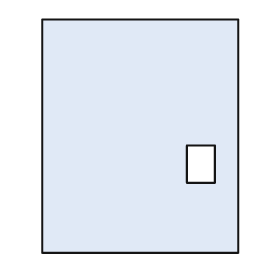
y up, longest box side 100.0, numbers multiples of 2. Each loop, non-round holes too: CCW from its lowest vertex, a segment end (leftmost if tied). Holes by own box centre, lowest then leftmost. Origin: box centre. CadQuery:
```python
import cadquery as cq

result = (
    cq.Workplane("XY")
    .moveTo(-42.0, -50.0)
    .lineTo(42.0, -50.0)
    .lineTo(42.0, 50.0)
    .lineTo(-42.0, 50.0)
    .close()
    .moveTo(20.0, -20.0)
    .lineTo(32.0, -20.0)
    .lineTo(32.0, -4.0)
    .lineTo(20.0, -4.0)
    .close()
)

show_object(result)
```